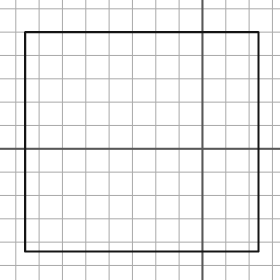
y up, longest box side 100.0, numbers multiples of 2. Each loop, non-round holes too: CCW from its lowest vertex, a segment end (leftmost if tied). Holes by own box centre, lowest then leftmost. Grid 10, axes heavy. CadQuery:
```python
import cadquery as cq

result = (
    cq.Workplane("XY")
    .moveTo(-76.0, -44.0)
    .lineTo(24.0, -44.0)
    .lineTo(24.0, 50.0)
    .lineTo(-76.0, 50.0)
    .close()
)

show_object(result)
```